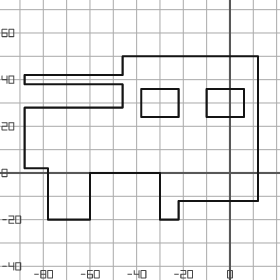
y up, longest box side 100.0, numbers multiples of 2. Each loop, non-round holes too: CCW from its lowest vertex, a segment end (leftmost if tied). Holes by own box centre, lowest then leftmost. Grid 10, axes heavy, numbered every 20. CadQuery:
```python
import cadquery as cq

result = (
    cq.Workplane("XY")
    .moveTo(-78.0, -20.0)
    .lineTo(-60.0, -20.0)
    .lineTo(-60.0, 0.0)
    .lineTo(-30.0, 0.0)
    .lineTo(-30.0, -20.0)
    .lineTo(-22.0, -20.0)
    .lineTo(-22.0, -12.0)
    .lineTo(12.0, -12.0)
    .lineTo(12.0, 50.0)
    .lineTo(-46.0, 50.0)
    .lineTo(-46.0, 42.0)
    .lineTo(-88.0, 42.0)
    .lineTo(-88.0, 38.0)
    .lineTo(-46.0, 38.0)
    .lineTo(-46.0, 28.0)
    .lineTo(-88.0, 28.0)
    .lineTo(-88.0, 2.0)
    .lineTo(-78.0, 2.0)
    .close()
    .moveTo(-38.0, 24.0)
    .lineTo(-22.0, 24.0)
    .lineTo(-22.0, 36.0)
    .lineTo(-38.0, 36.0)
    .close()
    .moveTo(-10.0, 24.0)
    .lineTo(6.0, 24.0)
    .lineTo(6.0, 36.0)
    .lineTo(-10.0, 36.0)
    .close()
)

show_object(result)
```